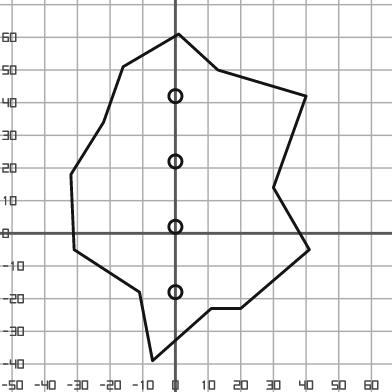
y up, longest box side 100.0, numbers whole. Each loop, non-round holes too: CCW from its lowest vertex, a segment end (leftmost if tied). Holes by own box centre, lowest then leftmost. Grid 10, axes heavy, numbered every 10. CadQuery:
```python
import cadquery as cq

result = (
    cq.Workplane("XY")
    .moveTo(-7.0, -39.0)
    .lineTo(11.0, -23.0)
    .lineTo(20.0, -23.0)
    .lineTo(41.0, -5.0)
    .lineTo(30.0, 14.0)
    .lineTo(40.0, 42.0)
    .lineTo(13.0, 50.0)
    .lineTo(1.0, 61.0)
    .lineTo(-16.0, 51.0)
    .lineTo(-22.0, 34.0)
    .lineTo(-32.0, 18.0)
    .lineTo(-31.0, -5.0)
    .lineTo(-11.0, -18.0)
    .close()
    .moveTo(0.0, -18.0)
    .circle(2.0)
    .moveTo(0.0, 2.0)
    .circle(2.0)
    .moveTo(0.0, 22.0)
    .circle(2.0)
    .moveTo(0.0, 42.0)
    .circle(2.0)
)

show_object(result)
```